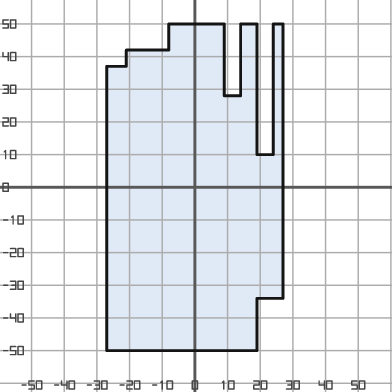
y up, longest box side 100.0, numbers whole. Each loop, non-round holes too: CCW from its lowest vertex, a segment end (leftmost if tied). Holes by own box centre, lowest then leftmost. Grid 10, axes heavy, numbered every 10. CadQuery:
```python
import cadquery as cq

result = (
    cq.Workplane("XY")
    .moveTo(-27.0, -50.0)
    .lineTo(19.0, -50.0)
    .lineTo(19.0, -34.0)
    .lineTo(27.0, -34.0)
    .lineTo(27.0, 50.0)
    .lineTo(24.0, 50.0)
    .lineTo(24.0, 10.0)
    .lineTo(19.0, 10.0)
    .lineTo(19.0, 50.0)
    .lineTo(14.0, 50.0)
    .lineTo(14.0, 28.0)
    .lineTo(9.0, 28.0)
    .lineTo(9.0, 50.0)
    .lineTo(-8.0, 50.0)
    .lineTo(-8.0, 42.0)
    .lineTo(-21.0, 42.0)
    .lineTo(-21.0, 37.0)
    .lineTo(-27.0, 37.0)
    .close()
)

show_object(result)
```